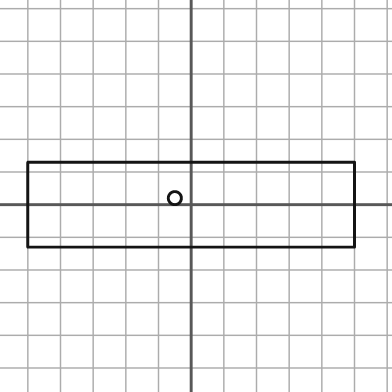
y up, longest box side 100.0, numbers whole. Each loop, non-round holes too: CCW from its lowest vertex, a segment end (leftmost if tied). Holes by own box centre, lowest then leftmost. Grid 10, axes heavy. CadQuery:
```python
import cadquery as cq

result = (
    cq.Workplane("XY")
    .moveTo(-50.0, -13.0)
    .lineTo(50.0, -13.0)
    .lineTo(50.0, 13.0)
    .lineTo(-50.0, 13.0)
    .close()
    .moveTo(-5.0, 2.0)
    .circle(2.0)
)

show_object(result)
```